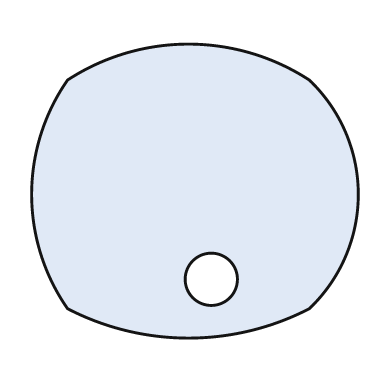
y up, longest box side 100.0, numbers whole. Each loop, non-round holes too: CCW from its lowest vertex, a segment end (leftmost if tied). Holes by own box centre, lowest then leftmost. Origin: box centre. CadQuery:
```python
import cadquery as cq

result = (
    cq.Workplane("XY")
    .moveTo(-39.0, -36.0)
    .threePointArc((-2.0, -45.0), (35.0, -36.0))
    .threePointArc((50.0, -1.0), (35.0, 34.0))
    .threePointArc((-2.0, 45.0), (-39.0, 34.0))
    .threePointArc((-50.0, -1.0), (-39.0, -36.0))
    .close()
    .moveTo(5.0, -27.0)
    .circle(8.0)
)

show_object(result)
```